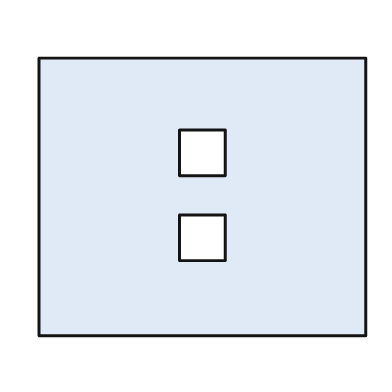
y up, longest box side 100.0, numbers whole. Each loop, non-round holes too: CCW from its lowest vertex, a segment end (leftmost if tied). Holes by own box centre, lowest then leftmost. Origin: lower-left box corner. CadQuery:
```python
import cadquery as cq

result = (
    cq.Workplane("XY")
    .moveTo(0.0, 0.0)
    .lineTo(100.0, 0.0)
    .lineTo(100.0, 85.0)
    .lineTo(0.0, 85.0)
    .close()
    .moveTo(43.0, 23.0)
    .lineTo(57.0, 23.0)
    .lineTo(57.0, 37.0)
    .lineTo(43.0, 37.0)
    .close()
    .moveTo(43.0, 49.0)
    .lineTo(57.0, 49.0)
    .lineTo(57.0, 63.0)
    .lineTo(43.0, 63.0)
    .close()
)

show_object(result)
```